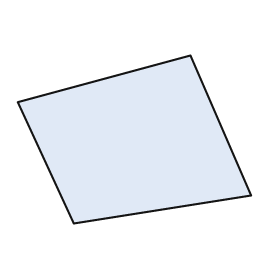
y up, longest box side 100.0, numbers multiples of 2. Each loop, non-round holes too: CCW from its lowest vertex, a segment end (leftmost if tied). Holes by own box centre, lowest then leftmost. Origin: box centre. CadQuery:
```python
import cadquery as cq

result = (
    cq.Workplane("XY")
    .moveTo(-26.0, -36.0)
    .lineTo(50.0, -24.0)
    .lineTo(24.0, 36.0)
    .lineTo(-50.0, 16.0)
    .close()
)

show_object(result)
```